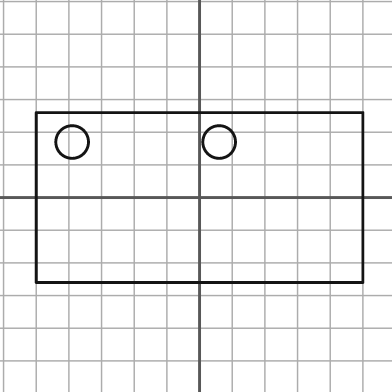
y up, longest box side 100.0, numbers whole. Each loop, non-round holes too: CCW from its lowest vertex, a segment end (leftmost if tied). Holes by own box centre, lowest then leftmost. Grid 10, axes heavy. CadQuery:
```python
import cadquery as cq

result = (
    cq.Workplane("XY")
    .moveTo(-50.0, -26.0)
    .lineTo(50.0, -26.0)
    .lineTo(50.0, 26.0)
    .lineTo(-50.0, 26.0)
    .close()
    .moveTo(-39.0, 17.0)
    .circle(5.0)
    .moveTo(6.0, 17.0)
    .circle(5.0)
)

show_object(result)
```